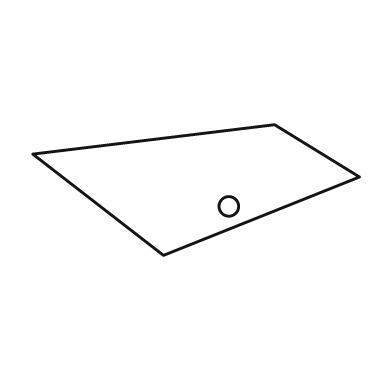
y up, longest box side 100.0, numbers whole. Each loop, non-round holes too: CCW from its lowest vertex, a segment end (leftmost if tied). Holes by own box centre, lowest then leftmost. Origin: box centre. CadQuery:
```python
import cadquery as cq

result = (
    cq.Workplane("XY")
    .moveTo(-10.0, -20.0)
    .lineTo(50.0, 4.0)
    .lineTo(24.0, 20.0)
    .lineTo(-50.0, 11.0)
    .close()
    .moveTo(10.0, -5.0)
    .circle(3.0)
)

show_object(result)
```